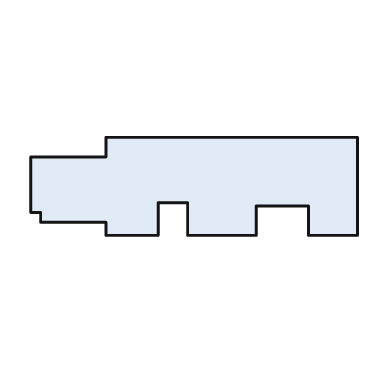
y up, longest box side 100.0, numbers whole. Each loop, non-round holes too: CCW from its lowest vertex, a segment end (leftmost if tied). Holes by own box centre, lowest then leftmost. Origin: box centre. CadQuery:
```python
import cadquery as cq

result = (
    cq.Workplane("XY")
    .moveTo(-27.0, -15.0)
    .lineTo(-11.0, -15.0)
    .lineTo(-11.0, -5.0)
    .lineTo(-2.0, -5.0)
    .lineTo(-2.0, -15.0)
    .lineTo(19.0, -15.0)
    .lineTo(19.0, -6.0)
    .lineTo(35.0, -6.0)
    .lineTo(35.0, -15.0)
    .lineTo(50.0, -15.0)
    .lineTo(50.0, 15.0)
    .lineTo(-27.0, 15.0)
    .lineTo(-27.0, 9.0)
    .lineTo(-50.0, 9.0)
    .lineTo(-50.0, -8.0)
    .lineTo(-47.0, -8.0)
    .lineTo(-47.0, -11.0)
    .lineTo(-27.0, -11.0)
    .close()
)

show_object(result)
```